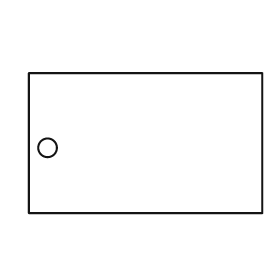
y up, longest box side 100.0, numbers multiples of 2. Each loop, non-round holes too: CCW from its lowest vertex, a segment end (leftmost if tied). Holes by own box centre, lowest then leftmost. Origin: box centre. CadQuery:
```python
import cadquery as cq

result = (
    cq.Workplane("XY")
    .moveTo(-50.0, -30.0)
    .lineTo(50.0, -30.0)
    .lineTo(50.0, 30.0)
    .lineTo(-50.0, 30.0)
    .close()
    .moveTo(-42.0, -2.0)
    .circle(4.0)
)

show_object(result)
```